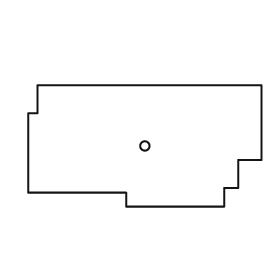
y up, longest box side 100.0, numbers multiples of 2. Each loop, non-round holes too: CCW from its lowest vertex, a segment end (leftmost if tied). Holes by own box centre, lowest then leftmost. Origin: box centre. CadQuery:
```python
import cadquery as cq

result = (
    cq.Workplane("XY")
    .moveTo(-8.0, -26.0)
    .lineTo(34.0, -26.0)
    .lineTo(34.0, -18.0)
    .lineTo(40.0, -18.0)
    .lineTo(40.0, -6.0)
    .lineTo(50.0, -6.0)
    .lineTo(50.0, 26.0)
    .lineTo(-46.0, 26.0)
    .lineTo(-46.0, 14.0)
    .lineTo(-50.0, 14.0)
    .lineTo(-50.0, -20.0)
    .lineTo(-8.0, -20.0)
    .close()
    .moveTo(0.0, 0.0)
    .circle(2.0)
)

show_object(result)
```